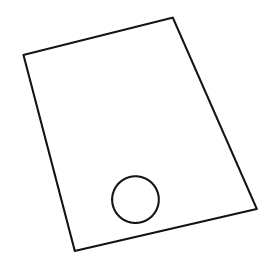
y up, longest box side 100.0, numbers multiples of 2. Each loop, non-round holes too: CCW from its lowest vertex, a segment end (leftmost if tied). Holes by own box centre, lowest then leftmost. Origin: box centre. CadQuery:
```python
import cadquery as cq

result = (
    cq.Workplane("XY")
    .moveTo(-28.0, -50.0)
    .lineTo(50.0, -32.0)
    .lineTo(14.0, 50.0)
    .lineTo(-50.0, 34.0)
    .close()
    .moveTo(-2.0, -28.0)
    .circle(10.0)
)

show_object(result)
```